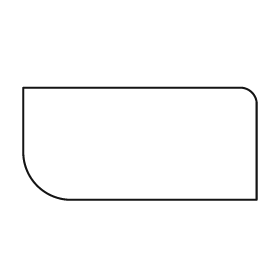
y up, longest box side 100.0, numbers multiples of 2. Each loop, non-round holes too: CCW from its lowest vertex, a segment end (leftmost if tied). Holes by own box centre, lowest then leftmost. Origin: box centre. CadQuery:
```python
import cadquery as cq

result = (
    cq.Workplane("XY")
    .moveTo(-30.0, -24.0)
    .lineTo(50.0, -24.0)
    .lineTo(50.0, 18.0)
    .threePointArc((48.0, 22.0), (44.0, 24.0))
    .lineTo(-50.0, 24.0)
    .lineTo(-50.0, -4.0)
    .threePointArc((-44.0, -18.0), (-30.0, -24.0))
    .close()
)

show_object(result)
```